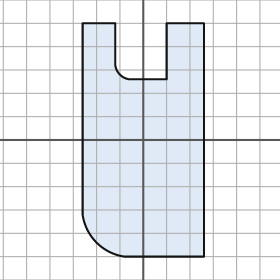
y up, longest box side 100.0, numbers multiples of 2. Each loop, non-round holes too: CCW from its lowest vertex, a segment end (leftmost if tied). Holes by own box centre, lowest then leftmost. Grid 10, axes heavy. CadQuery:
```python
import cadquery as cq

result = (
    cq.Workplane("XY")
    .moveTo(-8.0, -50.0)
    .lineTo(26.0, -50.0)
    .lineTo(26.0, 50.0)
    .lineTo(10.0, 50.0)
    .lineTo(10.0, 26.0)
    .lineTo(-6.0, 26.0)
    .threePointArc((-10.0, 28.0), (-12.0, 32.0))
    .lineTo(-12.0, 50.0)
    .lineTo(-26.0, 50.0)
    .lineTo(-26.0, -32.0)
    .threePointArc((-20.0, -44.0), (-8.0, -50.0))
    .close()
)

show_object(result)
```